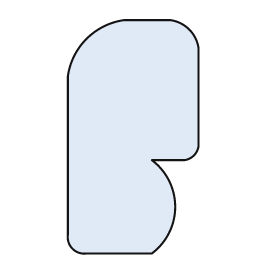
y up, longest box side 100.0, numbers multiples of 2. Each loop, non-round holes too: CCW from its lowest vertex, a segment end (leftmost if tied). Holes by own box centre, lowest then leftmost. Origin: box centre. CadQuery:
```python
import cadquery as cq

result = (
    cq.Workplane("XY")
    .moveTo(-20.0, -50.0)
    .lineTo(8.0, -50.0)
    .threePointArc((18.0, -30.0), (8.0, -10.0))
    .lineTo(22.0, -10.0)
    .threePointArc((26.0, -8.0), (28.0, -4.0))
    .lineTo(28.0, 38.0)
    .threePointArc((24.0, 46.0), (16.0, 50.0))
    .lineTo(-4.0, 50.0)
    .threePointArc((-20.0, 42.0), (-28.0, 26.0))
    .lineTo(-28.0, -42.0)
    .threePointArc((-26.0, -48.0), (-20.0, -50.0))
    .close()
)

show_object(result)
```